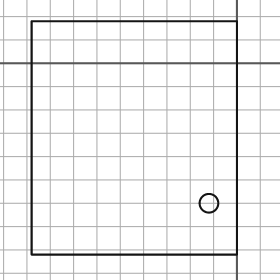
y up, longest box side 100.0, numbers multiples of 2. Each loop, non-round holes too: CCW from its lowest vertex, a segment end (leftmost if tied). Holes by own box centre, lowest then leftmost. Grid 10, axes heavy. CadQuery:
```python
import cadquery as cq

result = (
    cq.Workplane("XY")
    .moveTo(-88.0, -82.0)
    .lineTo(0.0, -82.0)
    .lineTo(0.0, 18.0)
    .lineTo(-88.0, 18.0)
    .close()
    .moveTo(-12.0, -60.0)
    .circle(4.0)
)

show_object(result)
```